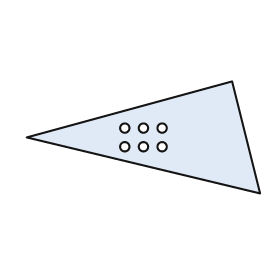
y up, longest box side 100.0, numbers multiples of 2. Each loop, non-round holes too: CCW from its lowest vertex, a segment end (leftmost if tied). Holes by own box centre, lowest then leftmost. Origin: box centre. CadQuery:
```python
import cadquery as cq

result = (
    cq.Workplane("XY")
    .moveTo(50.0, -24.0)
    .lineTo(38.0, 24.0)
    .lineTo(-50.0, 0.0)
    .close()
    .moveTo(-8.0, -4.0)
    .circle(2.0)
    .moveTo(0.0, -4.0)
    .circle(2.0)
    .moveTo(8.0, -4.0)
    .circle(2.0)
    .moveTo(-8.0, 4.0)
    .circle(2.0)
    .moveTo(0.0, 4.0)
    .circle(2.0)
    .moveTo(8.0, 4.0)
    .circle(2.0)
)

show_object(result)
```